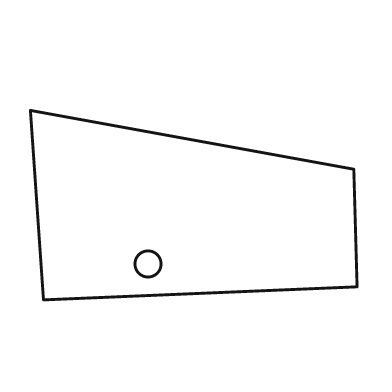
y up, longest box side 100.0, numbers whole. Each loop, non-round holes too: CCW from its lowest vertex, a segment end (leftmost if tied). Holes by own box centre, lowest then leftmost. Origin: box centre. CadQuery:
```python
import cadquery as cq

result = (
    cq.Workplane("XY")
    .moveTo(-46.0, -29.0)
    .lineTo(50.0, -25.0)
    .lineTo(49.0, 11.0)
    .lineTo(-50.0, 29.0)
    .close()
    .moveTo(-14.0, -18.0)
    .circle(4.0)
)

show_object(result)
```